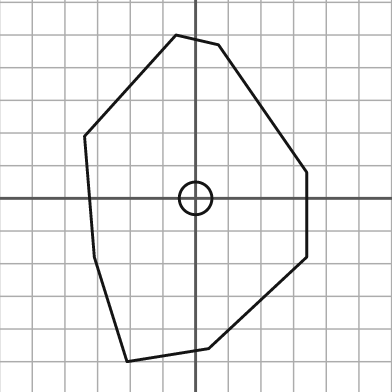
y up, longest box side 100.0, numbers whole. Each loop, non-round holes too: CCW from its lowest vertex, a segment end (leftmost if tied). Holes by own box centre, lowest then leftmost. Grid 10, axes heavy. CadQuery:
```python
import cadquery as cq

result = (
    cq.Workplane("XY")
    .moveTo(-21.0, -50.0)
    .lineTo(4.0, -46.0)
    .lineTo(34.0, -18.0)
    .lineTo(34.0, 8.0)
    .lineTo(7.0, 47.0)
    .lineTo(-6.0, 50.0)
    .lineTo(-34.0, 19.0)
    .lineTo(-31.0, -18.0)
    .close()
    .moveTo(0.0, 0.0)
    .circle(5.0)
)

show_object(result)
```